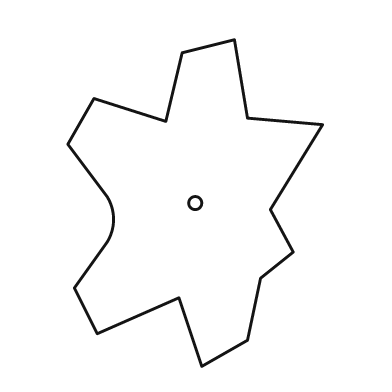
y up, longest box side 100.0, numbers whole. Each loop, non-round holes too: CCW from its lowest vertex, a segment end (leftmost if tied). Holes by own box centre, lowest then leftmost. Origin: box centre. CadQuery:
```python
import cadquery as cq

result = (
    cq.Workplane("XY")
    .moveTo(2.0, -50.0)
    .lineTo(16.0, -42.0)
    .lineTo(20.0, -23.0)
    .lineTo(30.0, -15.0)
    .lineTo(23.0, -2.0)
    .lineTo(39.0, 24.0)
    .lineTo(16.0, 26.0)
    .lineTo(12.0, 50.0)
    .lineTo(-4.0, 46.0)
    .lineTo(-9.0, 25.0)
    .lineTo(-31.0, 32.0)
    .lineTo(-39.0, 18.0)
    .lineTo(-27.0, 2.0)
    .threePointArc((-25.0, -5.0), (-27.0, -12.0))
    .lineTo(-37.0, -26.0)
    .lineTo(-30.0, -40.0)
    .lineTo(-5.0, -29.0)
    .close()
    .moveTo(0.0, 0.0)
    .circle(2.0)
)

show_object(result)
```